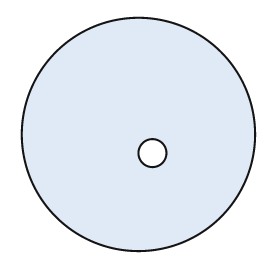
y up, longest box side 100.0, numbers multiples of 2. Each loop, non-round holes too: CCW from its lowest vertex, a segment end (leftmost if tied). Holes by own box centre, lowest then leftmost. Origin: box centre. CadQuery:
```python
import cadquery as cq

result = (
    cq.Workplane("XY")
    .moveTo(0.0, 0.0)
    .circle(50.0)
    .moveTo(6.0, -8.0)
    .circle(6.0)
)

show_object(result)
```